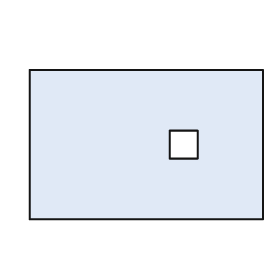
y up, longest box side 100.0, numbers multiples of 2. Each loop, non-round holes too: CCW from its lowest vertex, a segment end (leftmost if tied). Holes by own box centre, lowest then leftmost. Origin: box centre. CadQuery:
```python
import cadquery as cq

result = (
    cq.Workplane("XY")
    .moveTo(-50.0, -32.0)
    .lineTo(50.0, -32.0)
    .lineTo(50.0, 32.0)
    .lineTo(-50.0, 32.0)
    .close()
    .moveTo(10.0, -6.0)
    .lineTo(22.0, -6.0)
    .lineTo(22.0, 6.0)
    .lineTo(10.0, 6.0)
    .close()
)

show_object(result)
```